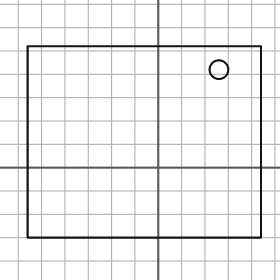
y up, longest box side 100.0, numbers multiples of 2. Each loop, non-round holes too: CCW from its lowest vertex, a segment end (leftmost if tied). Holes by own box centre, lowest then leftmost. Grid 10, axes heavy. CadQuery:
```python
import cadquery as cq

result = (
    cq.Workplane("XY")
    .moveTo(-56.0, -30.0)
    .lineTo(44.0, -30.0)
    .lineTo(44.0, 52.0)
    .lineTo(-56.0, 52.0)
    .close()
    .moveTo(26.0, 42.0)
    .circle(4.0)
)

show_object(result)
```